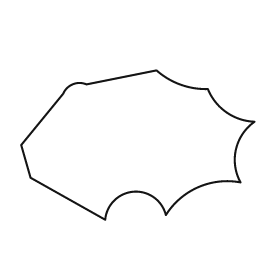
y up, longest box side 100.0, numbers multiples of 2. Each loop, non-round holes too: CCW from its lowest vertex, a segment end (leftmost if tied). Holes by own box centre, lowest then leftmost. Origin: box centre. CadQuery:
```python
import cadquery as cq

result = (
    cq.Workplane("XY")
    .moveTo(-14.0, -32.0)
    .threePointArc((-2.0, -20.0), (12.0, -30.0))
    .threePointArc((26.0, -18.0), (44.0, -16.0))
    .threePointArc((42.0, -2.0), (50.0, 10.0))
    .threePointArc((38.0, 14.0), (30.0, 24.0))
    .threePointArc((18.0, 26.0), (8.0, 32.0))
    .lineTo(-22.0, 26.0)
    .threePointArc((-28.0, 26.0), (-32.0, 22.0))
    .lineTo(-50.0, 0.0)
    .lineTo(-46.0, -14.0)
    .close()
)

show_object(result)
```